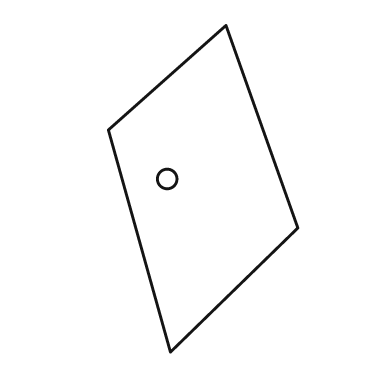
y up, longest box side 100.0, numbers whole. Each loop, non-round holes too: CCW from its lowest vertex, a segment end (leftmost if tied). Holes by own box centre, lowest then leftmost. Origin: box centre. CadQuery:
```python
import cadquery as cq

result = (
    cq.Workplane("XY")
    .moveTo(-10.0, -50.0)
    .lineTo(29.0, -12.0)
    .lineTo(7.0, 50.0)
    .lineTo(-29.0, 18.0)
    .close()
    .moveTo(-11.0, 3.0)
    .circle(3.0)
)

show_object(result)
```